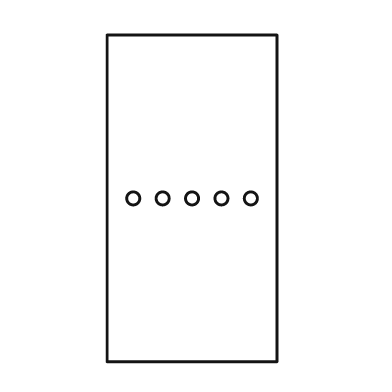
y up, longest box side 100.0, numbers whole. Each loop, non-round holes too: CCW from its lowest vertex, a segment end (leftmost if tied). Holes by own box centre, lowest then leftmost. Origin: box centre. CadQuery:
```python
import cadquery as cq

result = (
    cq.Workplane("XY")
    .moveTo(-26.0, -50.0)
    .lineTo(26.0, -50.0)
    .lineTo(26.0, 50.0)
    .lineTo(-26.0, 50.0)
    .close()
    .moveTo(-18.0, 0.0)
    .circle(2.0)
    .moveTo(-9.0, 0.0)
    .circle(2.0)
    .moveTo(0.0, 0.0)
    .circle(2.0)
    .moveTo(9.0, 0.0)
    .circle(2.0)
    .moveTo(18.0, 0.0)
    .circle(2.0)
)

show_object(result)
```